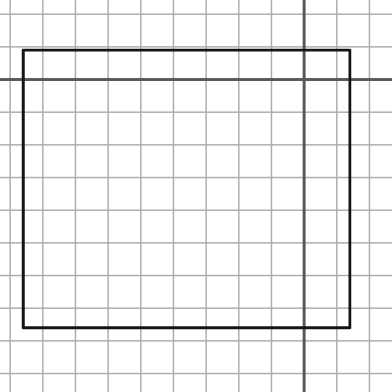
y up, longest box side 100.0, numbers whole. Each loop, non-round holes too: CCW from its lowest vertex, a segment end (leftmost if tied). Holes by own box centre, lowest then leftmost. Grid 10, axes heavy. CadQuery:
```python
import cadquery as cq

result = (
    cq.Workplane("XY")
    .moveTo(-86.0, -76.0)
    .lineTo(14.0, -76.0)
    .lineTo(14.0, 9.0)
    .lineTo(-86.0, 9.0)
    .close()
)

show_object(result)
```